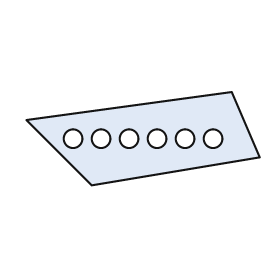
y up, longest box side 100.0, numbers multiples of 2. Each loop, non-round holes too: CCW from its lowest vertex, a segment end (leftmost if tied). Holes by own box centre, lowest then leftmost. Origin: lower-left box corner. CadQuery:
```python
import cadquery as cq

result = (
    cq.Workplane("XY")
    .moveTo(28.0, 0.0)
    .lineTo(100.0, 12.0)
    .lineTo(88.0, 40.0)
    .lineTo(0.0, 28.0)
    .close()
    .moveTo(20.0, 20.0)
    .circle(4.0)
    .moveTo(32.0, 20.0)
    .circle(4.0)
    .moveTo(44.0, 20.0)
    .circle(4.0)
    .moveTo(56.0, 20.0)
    .circle(4.0)
    .moveTo(68.0, 20.0)
    .circle(4.0)
    .moveTo(80.0, 20.0)
    .circle(4.0)
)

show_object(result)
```